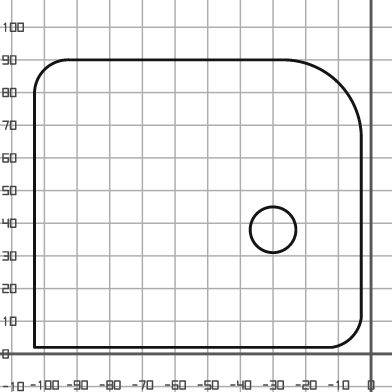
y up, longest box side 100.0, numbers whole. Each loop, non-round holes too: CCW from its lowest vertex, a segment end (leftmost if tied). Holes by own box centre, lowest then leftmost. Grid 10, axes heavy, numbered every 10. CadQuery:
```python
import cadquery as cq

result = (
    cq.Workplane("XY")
    .moveTo(-103.0, 2.0)
    .lineTo(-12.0, 2.0)
    .threePointArc((-6.0, 5.0), (-3.0, 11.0))
    .lineTo(-3.0, 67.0)
    .threePointArc((-10.0, 83.0), (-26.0, 90.0))
    .lineTo(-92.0, 90.0)
    .threePointArc((-100.0, 87.0), (-103.0, 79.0))
    .close()
    .moveTo(-30.0, 38.0)
    .circle(7.0)
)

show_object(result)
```